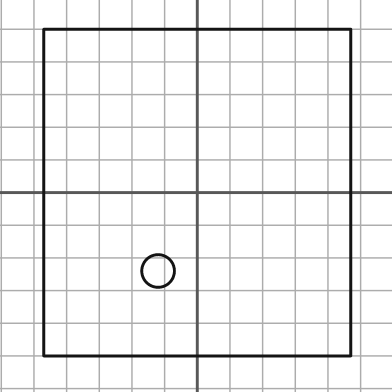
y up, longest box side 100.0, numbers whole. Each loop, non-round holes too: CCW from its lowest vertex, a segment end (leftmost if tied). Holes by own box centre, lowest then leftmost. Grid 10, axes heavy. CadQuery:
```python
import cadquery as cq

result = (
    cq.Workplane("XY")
    .moveTo(-47.0, -50.0)
    .lineTo(47.0, -50.0)
    .lineTo(47.0, 50.0)
    .lineTo(-47.0, 50.0)
    .close()
    .moveTo(-12.0, -24.0)
    .circle(5.0)
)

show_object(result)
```